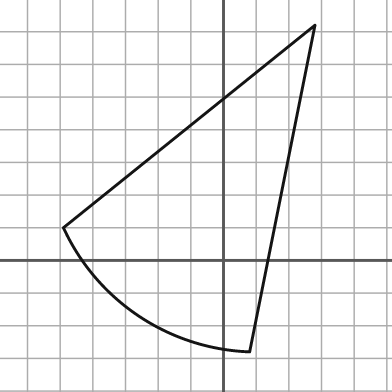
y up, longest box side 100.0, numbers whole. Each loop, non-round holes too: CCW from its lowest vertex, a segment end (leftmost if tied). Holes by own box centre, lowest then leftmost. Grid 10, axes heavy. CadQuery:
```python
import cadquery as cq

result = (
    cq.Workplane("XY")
    .moveTo(8.0, -28.0)
    .lineTo(28.0, 72.0)
    .lineTo(-49.0, 10.0)
    .threePointArc((-26.0, -17.0), (8.0, -28.0))
    .close()
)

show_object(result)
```